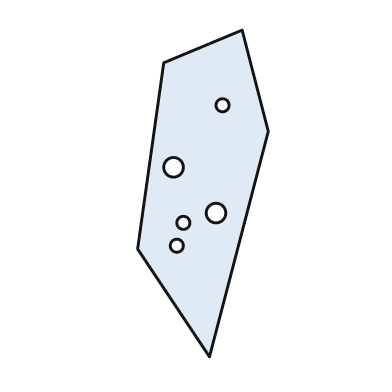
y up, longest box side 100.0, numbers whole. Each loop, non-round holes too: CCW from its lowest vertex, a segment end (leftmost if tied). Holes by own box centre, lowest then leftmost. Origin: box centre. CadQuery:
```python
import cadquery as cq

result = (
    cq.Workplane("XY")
    .moveTo(2.0, -50.0)
    .lineTo(20.0, 19.0)
    .lineTo(12.0, 50.0)
    .lineTo(-12.0, 40.0)
    .lineTo(-20.0, -17.0)
    .close()
    .moveTo(-8.0, -16.0)
    .circle(2.0)
    .moveTo(-6.0, -9.0)
    .circle(2.0)
    .moveTo(4.0, -6.0)
    .circle(3.0)
    .moveTo(-9.0, 8.0)
    .circle(3.0)
    .moveTo(6.0, 27.0)
    .circle(2.0)
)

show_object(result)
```